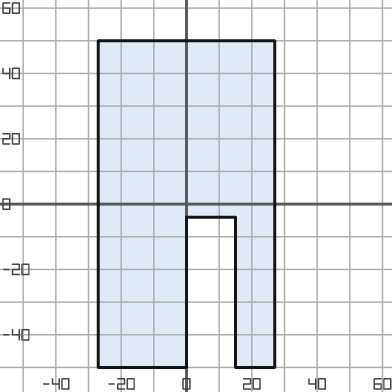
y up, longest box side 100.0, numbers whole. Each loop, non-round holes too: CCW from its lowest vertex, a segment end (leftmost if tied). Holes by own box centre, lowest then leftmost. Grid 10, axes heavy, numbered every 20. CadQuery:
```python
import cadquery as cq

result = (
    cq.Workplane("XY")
    .moveTo(-27.0, -50.0)
    .lineTo(0.0, -50.0)
    .lineTo(0.0, -4.0)
    .lineTo(15.0, -4.0)
    .lineTo(15.0, -50.0)
    .lineTo(27.0, -50.0)
    .lineTo(27.0, 50.0)
    .lineTo(-27.0, 50.0)
    .close()
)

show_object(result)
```